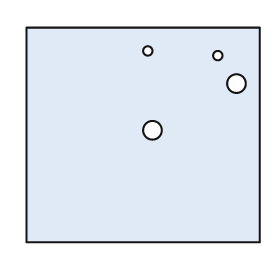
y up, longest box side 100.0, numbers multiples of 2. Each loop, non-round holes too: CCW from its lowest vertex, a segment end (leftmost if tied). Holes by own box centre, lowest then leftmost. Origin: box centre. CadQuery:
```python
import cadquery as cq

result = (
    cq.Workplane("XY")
    .moveTo(-50.0, -46.0)
    .lineTo(50.0, -46.0)
    .lineTo(50.0, 46.0)
    .lineTo(-50.0, 46.0)
    .close()
    .moveTo(4.0, 2.0)
    .circle(4.0)
    .moveTo(40.0, 22.0)
    .circle(4.0)
    .moveTo(32.0, 34.0)
    .circle(2.0)
    .moveTo(2.0, 36.0)
    .circle(2.0)
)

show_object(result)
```